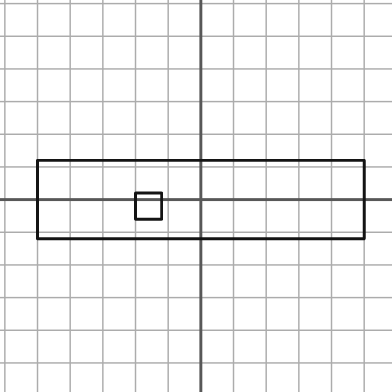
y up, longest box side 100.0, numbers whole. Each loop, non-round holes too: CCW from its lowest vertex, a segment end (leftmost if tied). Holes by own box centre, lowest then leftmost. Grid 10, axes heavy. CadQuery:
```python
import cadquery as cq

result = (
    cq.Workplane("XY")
    .moveTo(-50.0, -12.0)
    .lineTo(50.0, -12.0)
    .lineTo(50.0, 12.0)
    .lineTo(-50.0, 12.0)
    .close()
    .moveTo(-20.0, -6.0)
    .lineTo(-12.0, -6.0)
    .lineTo(-12.0, 2.0)
    .lineTo(-20.0, 2.0)
    .close()
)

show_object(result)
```